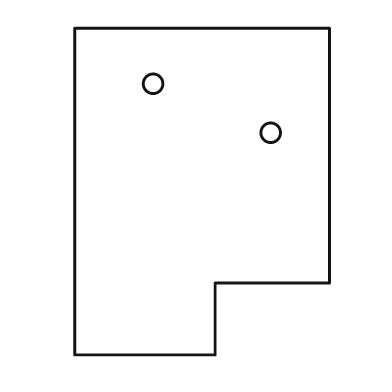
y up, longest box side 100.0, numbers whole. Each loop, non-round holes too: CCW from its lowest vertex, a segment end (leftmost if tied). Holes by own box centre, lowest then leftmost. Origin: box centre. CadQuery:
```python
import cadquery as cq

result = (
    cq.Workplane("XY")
    .moveTo(-39.0, -50.0)
    .lineTo(4.0, -50.0)
    .lineTo(4.0, -28.0)
    .lineTo(39.0, -28.0)
    .lineTo(39.0, 50.0)
    .lineTo(-39.0, 50.0)
    .close()
    .moveTo(21.0, 18.0)
    .circle(3.0)
    .moveTo(-15.0, 33.0)
    .circle(3.0)
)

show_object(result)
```